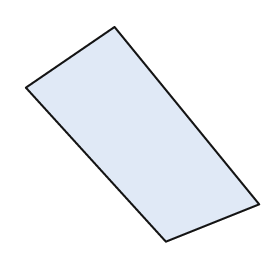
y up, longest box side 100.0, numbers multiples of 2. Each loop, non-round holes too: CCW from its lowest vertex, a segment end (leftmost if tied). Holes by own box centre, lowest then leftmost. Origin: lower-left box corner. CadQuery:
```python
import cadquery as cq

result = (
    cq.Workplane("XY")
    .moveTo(60.0, 0.0)
    .lineTo(100.0, 16.0)
    .lineTo(38.0, 92.0)
    .lineTo(0.0, 66.0)
    .close()
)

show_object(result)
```